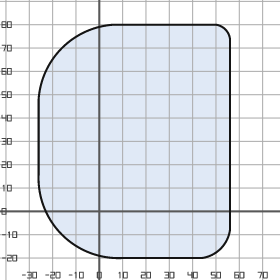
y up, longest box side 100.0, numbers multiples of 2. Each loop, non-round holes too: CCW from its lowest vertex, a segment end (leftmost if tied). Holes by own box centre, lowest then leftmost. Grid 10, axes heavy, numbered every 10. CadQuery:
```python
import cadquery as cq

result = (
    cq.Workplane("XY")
    .moveTo(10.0, -20.0)
    .lineTo(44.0, -20.0)
    .threePointArc((52.0, -16.0), (56.0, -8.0))
    .lineTo(56.0, 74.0)
    .threePointArc((54.0, 78.0), (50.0, 80.0))
    .lineTo(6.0, 80.0)
    .threePointArc((-16.0, 70.0), (-26.0, 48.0))
    .lineTo(-26.0, 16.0)
    .threePointArc((-16.0, -10.0), (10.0, -20.0))
    .close()
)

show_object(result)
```